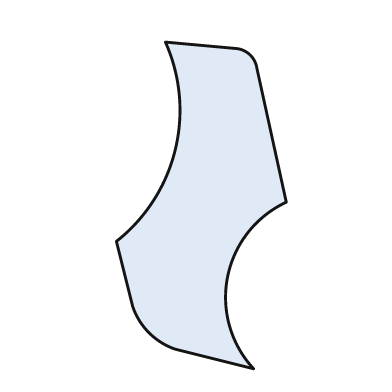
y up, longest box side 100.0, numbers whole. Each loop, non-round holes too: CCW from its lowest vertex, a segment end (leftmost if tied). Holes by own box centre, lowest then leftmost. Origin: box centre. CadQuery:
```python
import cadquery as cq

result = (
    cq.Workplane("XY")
    .moveTo(16.0, -50.0)
    .threePointArc((8.0, -22.0), (26.0, 1.0))
    .lineTo(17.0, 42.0)
    .threePointArc((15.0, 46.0), (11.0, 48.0))
    .lineTo(-11.0, 50.0)
    .threePointArc((-8.0, 17.0), (-26.0, -11.0))
    .lineTo(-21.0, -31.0)
    .threePointArc((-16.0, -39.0), (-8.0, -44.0))
    .close()
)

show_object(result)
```